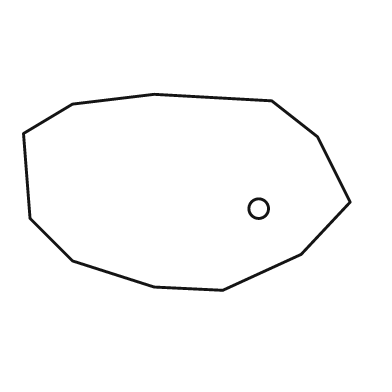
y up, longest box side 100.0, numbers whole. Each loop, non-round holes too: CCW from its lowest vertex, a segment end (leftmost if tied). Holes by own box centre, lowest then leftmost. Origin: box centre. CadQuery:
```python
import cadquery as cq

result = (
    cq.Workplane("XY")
    .moveTo(11.0, -30.0)
    .lineTo(35.0, -19.0)
    .lineTo(50.0, -3.0)
    .lineTo(40.0, 17.0)
    .lineTo(26.0, 28.0)
    .lineTo(-10.0, 30.0)
    .lineTo(-35.0, 27.0)
    .lineTo(-50.0, 18.0)
    .lineTo(-48.0, -8.0)
    .lineTo(-35.0, -21.0)
    .lineTo(-10.0, -29.0)
    .close()
    .moveTo(22.0, -5.0)
    .circle(3.0)
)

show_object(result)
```